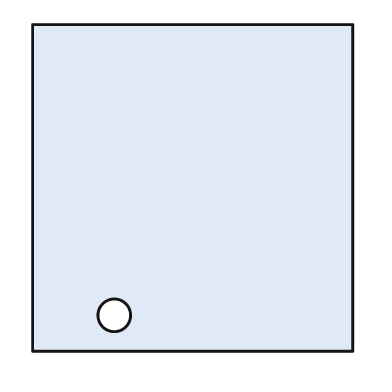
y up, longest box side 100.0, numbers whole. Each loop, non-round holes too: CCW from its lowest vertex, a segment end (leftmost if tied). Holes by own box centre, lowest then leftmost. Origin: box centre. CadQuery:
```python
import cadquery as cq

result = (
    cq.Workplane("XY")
    .moveTo(-49.0, -50.0)
    .lineTo(49.0, -50.0)
    .lineTo(49.0, 50.0)
    .lineTo(-49.0, 50.0)
    .close()
    .moveTo(-24.0, -39.0)
    .circle(5.0)
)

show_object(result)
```